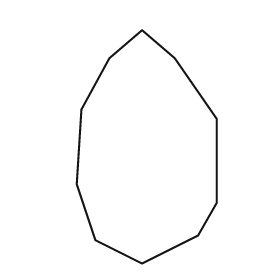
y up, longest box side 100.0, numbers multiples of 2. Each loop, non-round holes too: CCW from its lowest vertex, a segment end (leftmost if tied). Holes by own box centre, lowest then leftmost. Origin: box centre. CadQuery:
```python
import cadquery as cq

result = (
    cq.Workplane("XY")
    .moveTo(-2.0, -50.0)
    .lineTo(22.0, -38.0)
    .lineTo(30.0, -24.0)
    .lineTo(30.0, 12.0)
    .lineTo(12.0, 38.0)
    .lineTo(-2.0, 50.0)
    .lineTo(-16.0, 38.0)
    .lineTo(-28.0, 16.0)
    .lineTo(-30.0, -16.0)
    .lineTo(-22.0, -40.0)
    .close()
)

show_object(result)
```